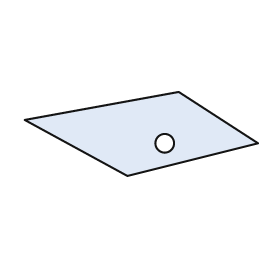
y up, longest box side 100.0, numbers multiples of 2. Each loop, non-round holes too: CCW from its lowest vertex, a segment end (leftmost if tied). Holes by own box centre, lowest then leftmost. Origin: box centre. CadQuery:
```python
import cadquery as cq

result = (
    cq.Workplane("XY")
    .moveTo(-6.0, -18.0)
    .lineTo(50.0, -4.0)
    .lineTo(16.0, 18.0)
    .lineTo(-50.0, 6.0)
    .close()
    .moveTo(10.0, -4.0)
    .circle(4.0)
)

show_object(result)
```